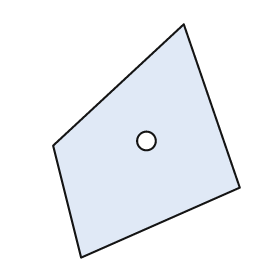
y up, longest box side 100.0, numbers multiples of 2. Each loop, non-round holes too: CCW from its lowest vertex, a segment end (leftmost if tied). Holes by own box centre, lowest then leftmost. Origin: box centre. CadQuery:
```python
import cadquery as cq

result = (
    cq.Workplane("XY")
    .moveTo(-28.0, -50.0)
    .lineTo(40.0, -20.0)
    .lineTo(16.0, 50.0)
    .lineTo(-40.0, -2.0)
    .close()
    .moveTo(0.0, 0.0)
    .circle(4.0)
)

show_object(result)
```